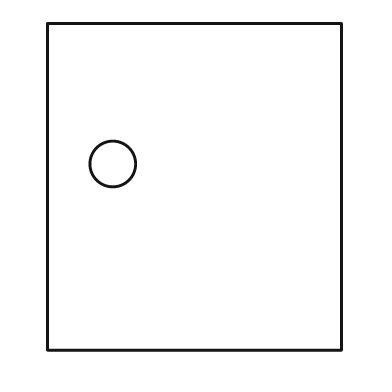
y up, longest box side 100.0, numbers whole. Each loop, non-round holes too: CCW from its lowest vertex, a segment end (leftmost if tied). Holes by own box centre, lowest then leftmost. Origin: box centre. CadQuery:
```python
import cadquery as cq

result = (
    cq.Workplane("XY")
    .moveTo(-45.0, -50.0)
    .lineTo(45.0, -50.0)
    .lineTo(45.0, 50.0)
    .lineTo(-45.0, 50.0)
    .close()
    .moveTo(-25.0, 7.0)
    .circle(7.0)
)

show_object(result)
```